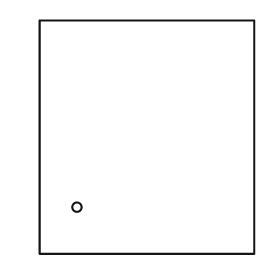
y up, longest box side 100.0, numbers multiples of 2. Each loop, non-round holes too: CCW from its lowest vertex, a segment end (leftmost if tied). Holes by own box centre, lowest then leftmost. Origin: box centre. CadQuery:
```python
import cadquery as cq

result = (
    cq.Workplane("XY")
    .moveTo(-46.0, -50.0)
    .lineTo(46.0, -50.0)
    .lineTo(46.0, 50.0)
    .lineTo(-46.0, 50.0)
    .close()
    .moveTo(-30.0, -30.0)
    .circle(2.0)
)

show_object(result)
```